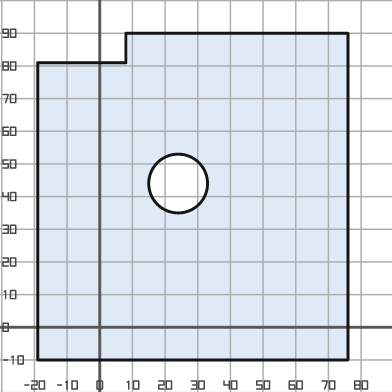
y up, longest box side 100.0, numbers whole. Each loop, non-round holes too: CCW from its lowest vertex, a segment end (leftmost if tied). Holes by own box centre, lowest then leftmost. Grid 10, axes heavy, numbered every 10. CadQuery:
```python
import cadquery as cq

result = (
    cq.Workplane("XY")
    .moveTo(-19.0, -10.0)
    .lineTo(76.0, -10.0)
    .lineTo(76.0, 90.0)
    .lineTo(8.0, 90.0)
    .lineTo(8.0, 81.0)
    .lineTo(-19.0, 81.0)
    .close()
    .moveTo(24.0, 44.0)
    .circle(9.0)
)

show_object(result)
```